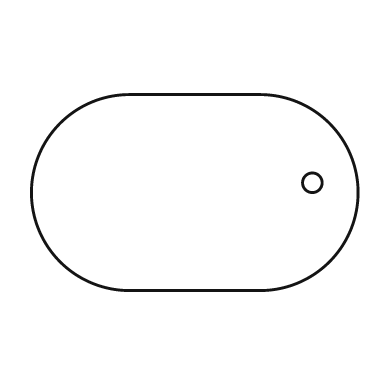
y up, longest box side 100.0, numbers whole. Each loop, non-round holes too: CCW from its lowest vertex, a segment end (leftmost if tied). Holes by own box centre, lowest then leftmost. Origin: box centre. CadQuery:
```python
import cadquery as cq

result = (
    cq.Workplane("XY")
    .moveTo(-20.0, -30.0)
    .lineTo(20.0, -30.0)
    .threePointArc((50.0, 0.0), (20.0, 30.0))
    .lineTo(-20.0, 30.0)
    .threePointArc((-50.0, 0.0), (-20.0, -30.0))
    .close()
    .moveTo(36.0, 3.0)
    .circle(3.0)
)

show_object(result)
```